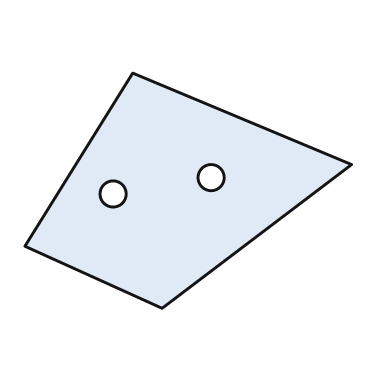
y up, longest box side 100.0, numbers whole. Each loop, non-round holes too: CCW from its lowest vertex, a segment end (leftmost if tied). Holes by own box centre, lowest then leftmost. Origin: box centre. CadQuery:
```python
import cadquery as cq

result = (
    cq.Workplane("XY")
    .moveTo(-8.0, -36.0)
    .lineTo(50.0, 8.0)
    .lineTo(-17.0, 36.0)
    .lineTo(-50.0, -17.0)
    .close()
    .moveTo(-23.0, -1.0)
    .circle(4.0)
    .moveTo(7.0, 4.0)
    .circle(4.0)
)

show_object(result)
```